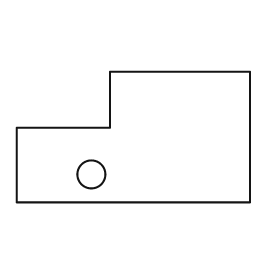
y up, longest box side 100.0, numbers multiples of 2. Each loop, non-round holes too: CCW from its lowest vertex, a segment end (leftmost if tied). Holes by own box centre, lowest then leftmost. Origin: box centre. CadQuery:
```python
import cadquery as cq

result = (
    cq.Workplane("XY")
    .moveTo(-50.0, -28.0)
    .lineTo(50.0, -28.0)
    .lineTo(50.0, 28.0)
    .lineTo(-10.0, 28.0)
    .lineTo(-10.0, 4.0)
    .lineTo(-50.0, 4.0)
    .close()
    .moveTo(-18.0, -16.0)
    .circle(6.0)
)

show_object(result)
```